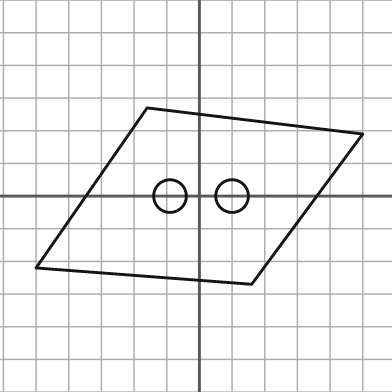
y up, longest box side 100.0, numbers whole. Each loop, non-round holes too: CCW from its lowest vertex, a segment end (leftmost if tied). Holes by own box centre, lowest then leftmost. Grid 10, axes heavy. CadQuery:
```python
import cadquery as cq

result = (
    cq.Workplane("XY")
    .moveTo(16.0, -27.0)
    .lineTo(50.0, 19.0)
    .lineTo(-16.0, 27.0)
    .lineTo(-50.0, -22.0)
    .close()
    .moveTo(-9.0, 0.0)
    .circle(5.0)
    .moveTo(10.0, 0.0)
    .circle(5.0)
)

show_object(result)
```